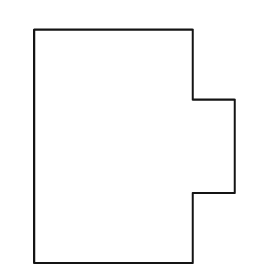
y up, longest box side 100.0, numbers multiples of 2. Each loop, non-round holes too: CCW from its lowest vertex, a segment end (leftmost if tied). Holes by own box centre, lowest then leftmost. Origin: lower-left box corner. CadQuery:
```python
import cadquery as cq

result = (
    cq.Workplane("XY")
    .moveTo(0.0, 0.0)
    .lineTo(68.0, 0.0)
    .lineTo(68.0, 30.0)
    .lineTo(86.0, 30.0)
    .lineTo(86.0, 70.0)
    .lineTo(68.0, 70.0)
    .lineTo(68.0, 100.0)
    .lineTo(0.0, 100.0)
    .close()
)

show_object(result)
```